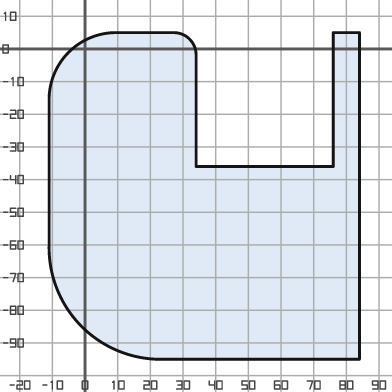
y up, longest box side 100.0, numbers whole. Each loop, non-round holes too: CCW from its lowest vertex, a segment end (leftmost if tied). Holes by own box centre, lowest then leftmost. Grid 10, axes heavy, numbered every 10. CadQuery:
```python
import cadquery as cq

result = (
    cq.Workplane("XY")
    .moveTo(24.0, -95.0)
    .lineTo(84.0, -95.0)
    .lineTo(84.0, 5.0)
    .lineTo(76.0, 5.0)
    .lineTo(76.0, -36.0)
    .lineTo(34.0, -36.0)
    .lineTo(34.0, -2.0)
    .threePointArc((32.0, 3.0), (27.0, 5.0))
    .lineTo(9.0, 5.0)
    .threePointArc((-5.0, -1.0), (-11.0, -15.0))
    .lineTo(-11.0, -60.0)
    .threePointArc((-1.0, -85.0), (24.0, -95.0))
    .close()
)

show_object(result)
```